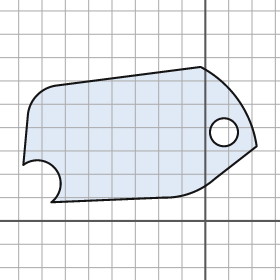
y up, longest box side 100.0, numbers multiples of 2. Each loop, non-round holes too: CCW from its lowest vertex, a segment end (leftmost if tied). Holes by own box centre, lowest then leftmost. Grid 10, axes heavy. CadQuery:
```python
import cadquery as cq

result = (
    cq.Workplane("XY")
    .moveTo(-66.0, 8.0)
    .lineTo(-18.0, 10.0)
    .threePointArc((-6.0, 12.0), (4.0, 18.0))
    .lineTo(22.0, 32.0)
    .threePointArc((14.0, 52.0), (-2.0, 66.0))
    .lineTo(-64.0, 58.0)
    .threePointArc((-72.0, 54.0), (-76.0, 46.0))
    .lineTo(-78.0, 24.0)
    .threePointArc((-64.0, 22.0), (-66.0, 8.0))
    .close()
    .moveTo(8.0, 38.0)
    .circle(6.0)
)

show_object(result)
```